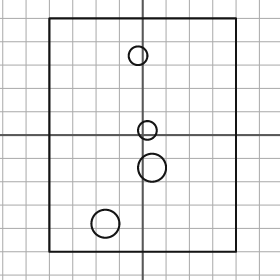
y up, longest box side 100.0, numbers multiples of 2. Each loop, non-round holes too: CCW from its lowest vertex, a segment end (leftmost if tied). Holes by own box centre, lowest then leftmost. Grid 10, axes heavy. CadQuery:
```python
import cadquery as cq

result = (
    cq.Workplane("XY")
    .moveTo(-40.0, -50.0)
    .lineTo(40.0, -50.0)
    .lineTo(40.0, 50.0)
    .lineTo(-40.0, 50.0)
    .close()
    .moveTo(-16.0, -38.0)
    .circle(6.0)
    .moveTo(4.0, -14.0)
    .circle(6.0)
    .moveTo(2.0, 2.0)
    .circle(4.0)
    .moveTo(-2.0, 34.0)
    .circle(4.0)
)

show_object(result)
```